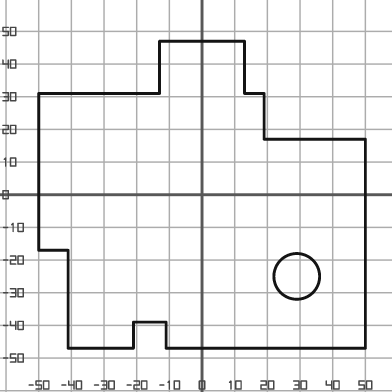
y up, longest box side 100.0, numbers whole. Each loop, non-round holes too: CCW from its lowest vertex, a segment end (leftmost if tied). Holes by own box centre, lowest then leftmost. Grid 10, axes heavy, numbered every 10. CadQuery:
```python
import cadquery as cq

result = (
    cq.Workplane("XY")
    .moveTo(-41.0, -47.0)
    .lineTo(-21.0, -47.0)
    .lineTo(-21.0, -39.0)
    .lineTo(-11.0, -39.0)
    .lineTo(-11.0, -47.0)
    .lineTo(50.0, -47.0)
    .lineTo(50.0, 17.0)
    .lineTo(19.0, 17.0)
    .lineTo(19.0, 31.0)
    .lineTo(13.0, 31.0)
    .lineTo(13.0, 47.0)
    .lineTo(-13.0, 47.0)
    .lineTo(-13.0, 31.0)
    .lineTo(-50.0, 31.0)
    .lineTo(-50.0, -17.0)
    .lineTo(-41.0, -17.0)
    .close()
    .moveTo(29.0, -25.0)
    .circle(7.0)
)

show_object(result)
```